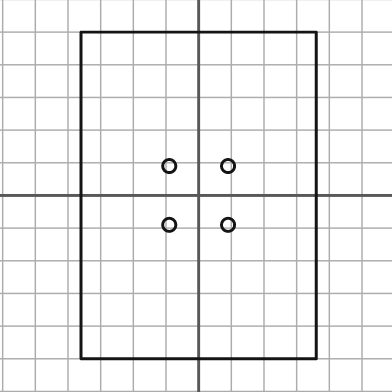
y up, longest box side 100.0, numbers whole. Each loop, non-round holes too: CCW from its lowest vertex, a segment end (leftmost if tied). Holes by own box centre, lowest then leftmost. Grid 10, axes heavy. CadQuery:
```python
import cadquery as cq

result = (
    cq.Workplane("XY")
    .moveTo(-36.0, -50.0)
    .lineTo(36.0, -50.0)
    .lineTo(36.0, 50.0)
    .lineTo(-36.0, 50.0)
    .close()
    .moveTo(-9.0, -9.0)
    .circle(2.0)
    .moveTo(9.0, -9.0)
    .circle(2.0)
    .moveTo(-9.0, 9.0)
    .circle(2.0)
    .moveTo(9.0, 9.0)
    .circle(2.0)
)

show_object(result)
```